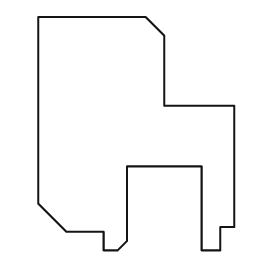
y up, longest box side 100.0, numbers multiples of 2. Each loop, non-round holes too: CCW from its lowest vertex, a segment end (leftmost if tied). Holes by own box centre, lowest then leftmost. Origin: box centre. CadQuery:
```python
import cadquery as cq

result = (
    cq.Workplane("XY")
    .moveTo(-14.0, -50.0)
    .lineTo(-8.0, -50.0)
    .lineTo(-4.0, -46.0)
    .lineTo(-4.0, -14.0)
    .lineTo(28.0, -14.0)
    .lineTo(28.0, -50.0)
    .lineTo(36.0, -50.0)
    .lineTo(36.0, -40.0)
    .lineTo(42.0, -40.0)
    .lineTo(42.0, 12.0)
    .lineTo(12.0, 12.0)
    .lineTo(12.0, 42.0)
    .lineTo(4.0, 50.0)
    .lineTo(-42.0, 50.0)
    .lineTo(-42.0, -30.0)
    .lineTo(-30.0, -42.0)
    .lineTo(-14.0, -42.0)
    .close()
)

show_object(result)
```